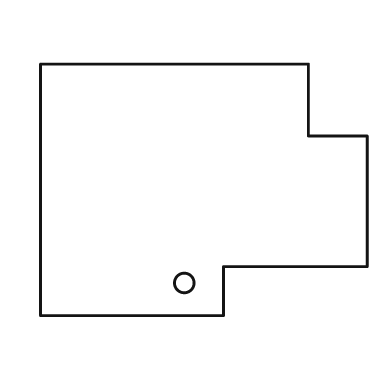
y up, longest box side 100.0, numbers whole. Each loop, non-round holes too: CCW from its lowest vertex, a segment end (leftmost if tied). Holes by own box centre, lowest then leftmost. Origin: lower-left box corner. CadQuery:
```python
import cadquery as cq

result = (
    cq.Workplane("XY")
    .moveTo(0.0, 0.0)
    .lineTo(56.0, 0.0)
    .lineTo(56.0, 15.0)
    .lineTo(100.0, 15.0)
    .lineTo(100.0, 55.0)
    .lineTo(82.0, 55.0)
    .lineTo(82.0, 77.0)
    .lineTo(0.0, 77.0)
    .close()
    .moveTo(44.0, 10.0)
    .circle(3.0)
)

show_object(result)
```